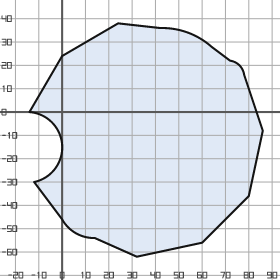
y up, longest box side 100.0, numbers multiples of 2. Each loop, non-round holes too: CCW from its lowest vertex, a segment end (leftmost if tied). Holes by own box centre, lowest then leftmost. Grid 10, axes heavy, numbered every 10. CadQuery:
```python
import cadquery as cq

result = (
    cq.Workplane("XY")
    .moveTo(32.0, -62.0)
    .lineTo(60.0, -56.0)
    .lineTo(80.0, -36.0)
    .lineTo(86.0, -8.0)
    .lineTo(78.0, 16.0)
    .threePointArc((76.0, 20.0), (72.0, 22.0))
    .lineTo(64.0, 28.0)
    .threePointArc((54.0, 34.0), (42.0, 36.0))
    .lineTo(24.0, 38.0)
    .lineTo(0.0, 24.0)
    .lineTo(-14.0, 0.0)
    .threePointArc((0.0, -14.0), (-12.0, -30.0))
    .lineTo(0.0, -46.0)
    .threePointArc((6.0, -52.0), (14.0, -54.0))
    .close()
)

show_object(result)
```